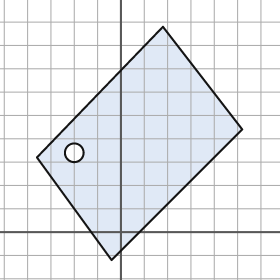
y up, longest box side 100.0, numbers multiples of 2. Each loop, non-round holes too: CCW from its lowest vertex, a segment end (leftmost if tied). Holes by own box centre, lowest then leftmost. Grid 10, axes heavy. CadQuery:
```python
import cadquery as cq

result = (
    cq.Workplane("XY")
    .moveTo(-4.0, -12.0)
    .lineTo(52.0, 44.0)
    .lineTo(18.0, 88.0)
    .lineTo(-36.0, 32.0)
    .close()
    .moveTo(-20.0, 34.0)
    .circle(4.0)
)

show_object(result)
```